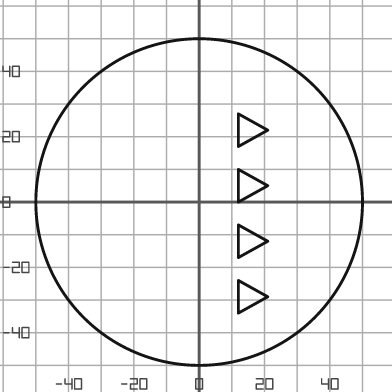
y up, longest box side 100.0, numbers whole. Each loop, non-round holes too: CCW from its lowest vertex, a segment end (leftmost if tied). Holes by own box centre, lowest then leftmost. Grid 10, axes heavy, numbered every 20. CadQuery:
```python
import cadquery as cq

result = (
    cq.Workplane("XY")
    .moveTo(0.0, 0.0)
    .circle(50.0)
    .moveTo(12.0, -34.0)
    .lineTo(21.0, -29.0)
    .lineTo(12.0, -24.0)
    .close()
    .moveTo(12.0, -17.0)
    .lineTo(21.0, -12.0)
    .lineTo(12.0, -7.0)
    .close()
    .moveTo(12.0, 0.0)
    .lineTo(21.0, 5.0)
    .lineTo(12.0, 10.0)
    .close()
    .moveTo(12.0, 17.0)
    .lineTo(21.0, 22.0)
    .lineTo(12.0, 27.0)
    .close()
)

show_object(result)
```